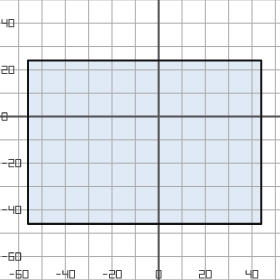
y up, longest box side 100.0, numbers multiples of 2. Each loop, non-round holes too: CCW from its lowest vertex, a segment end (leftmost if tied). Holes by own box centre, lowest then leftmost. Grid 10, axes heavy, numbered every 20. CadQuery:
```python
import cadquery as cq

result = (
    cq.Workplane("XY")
    .moveTo(-56.0, -46.0)
    .lineTo(44.0, -46.0)
    .lineTo(44.0, 24.0)
    .lineTo(-56.0, 24.0)
    .close()
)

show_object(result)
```